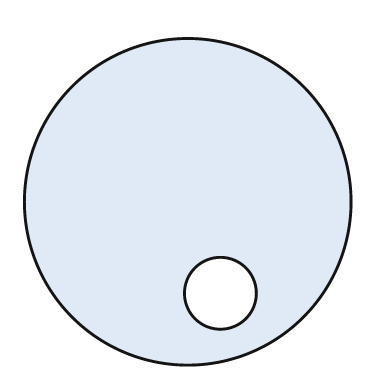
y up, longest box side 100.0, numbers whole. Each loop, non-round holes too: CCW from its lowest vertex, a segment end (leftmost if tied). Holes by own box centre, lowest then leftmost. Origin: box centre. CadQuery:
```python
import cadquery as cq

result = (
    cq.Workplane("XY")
    .moveTo(0.0, 0.0)
    .circle(50.0)
    .moveTo(10.0, -28.0)
    .circle(11.0)
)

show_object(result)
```